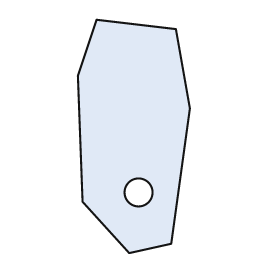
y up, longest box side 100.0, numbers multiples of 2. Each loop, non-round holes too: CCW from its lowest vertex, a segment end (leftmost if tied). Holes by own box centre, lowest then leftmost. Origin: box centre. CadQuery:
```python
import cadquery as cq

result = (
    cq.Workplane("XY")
    .moveTo(-2.0, -50.0)
    .lineTo(16.0, -46.0)
    .lineTo(24.0, 12.0)
    .lineTo(18.0, 46.0)
    .lineTo(-16.0, 50.0)
    .lineTo(-24.0, 26.0)
    .lineTo(-22.0, -28.0)
    .close()
    .moveTo(2.0, -24.0)
    .circle(6.0)
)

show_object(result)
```